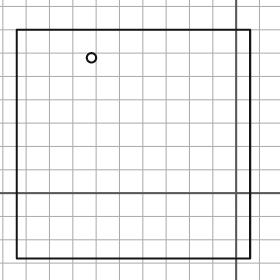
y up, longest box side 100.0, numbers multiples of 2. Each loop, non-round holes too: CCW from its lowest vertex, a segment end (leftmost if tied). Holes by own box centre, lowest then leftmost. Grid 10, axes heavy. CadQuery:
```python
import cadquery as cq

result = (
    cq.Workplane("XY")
    .moveTo(-94.0, -28.0)
    .lineTo(6.0, -28.0)
    .lineTo(6.0, 70.0)
    .lineTo(-94.0, 70.0)
    .close()
    .moveTo(-62.0, 58.0)
    .circle(2.0)
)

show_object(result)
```